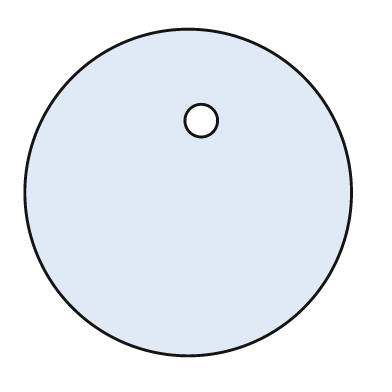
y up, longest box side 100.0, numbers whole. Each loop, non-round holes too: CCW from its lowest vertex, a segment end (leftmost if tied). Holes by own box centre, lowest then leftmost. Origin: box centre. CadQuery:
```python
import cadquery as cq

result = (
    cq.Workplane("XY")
    .moveTo(0.0, 0.0)
    .circle(50.0)
    .moveTo(4.0, 22.0)
    .circle(5.0)
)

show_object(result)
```